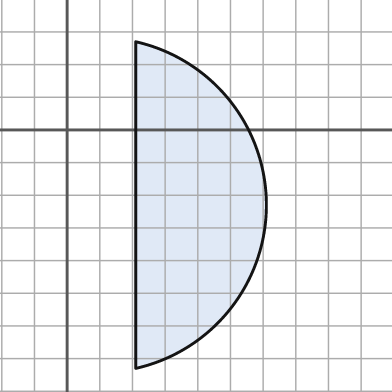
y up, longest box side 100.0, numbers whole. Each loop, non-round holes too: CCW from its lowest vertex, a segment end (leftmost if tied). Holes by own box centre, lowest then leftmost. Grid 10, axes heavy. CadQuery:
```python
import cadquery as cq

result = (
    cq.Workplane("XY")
    .moveTo(21.0, -73.0)
    .threePointArc((61.0, -23.0), (21.0, 27.0))
    .close()
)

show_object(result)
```